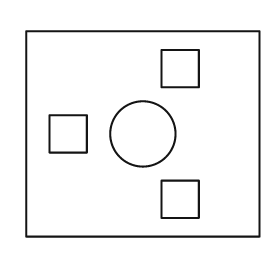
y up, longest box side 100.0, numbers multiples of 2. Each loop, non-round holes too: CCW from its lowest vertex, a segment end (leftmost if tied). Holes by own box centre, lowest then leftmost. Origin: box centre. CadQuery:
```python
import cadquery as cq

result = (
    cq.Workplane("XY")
    .moveTo(-50.0, -44.0)
    .lineTo(50.0, -44.0)
    .lineTo(50.0, 44.0)
    .lineTo(-50.0, 44.0)
    .close()
    .moveTo(8.0, -36.0)
    .lineTo(24.0, -36.0)
    .lineTo(24.0, -20.0)
    .lineTo(8.0, -20.0)
    .close()
    .moveTo(-40.0, -8.0)
    .lineTo(-24.0, -8.0)
    .lineTo(-24.0, 8.0)
    .lineTo(-40.0, 8.0)
    .close()
    .moveTo(0.0, 0.0)
    .circle(14.0)
    .moveTo(8.0, 20.0)
    .lineTo(24.0, 20.0)
    .lineTo(24.0, 36.0)
    .lineTo(8.0, 36.0)
    .close()
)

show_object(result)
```